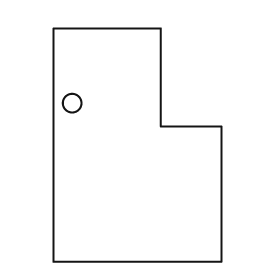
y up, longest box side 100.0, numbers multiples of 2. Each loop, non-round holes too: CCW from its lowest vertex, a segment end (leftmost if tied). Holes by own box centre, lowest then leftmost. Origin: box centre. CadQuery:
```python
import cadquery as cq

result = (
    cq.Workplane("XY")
    .moveTo(-36.0, -50.0)
    .lineTo(36.0, -50.0)
    .lineTo(36.0, 8.0)
    .lineTo(10.0, 8.0)
    .lineTo(10.0, 50.0)
    .lineTo(-36.0, 50.0)
    .close()
    .moveTo(-28.0, 18.0)
    .circle(4.0)
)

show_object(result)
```